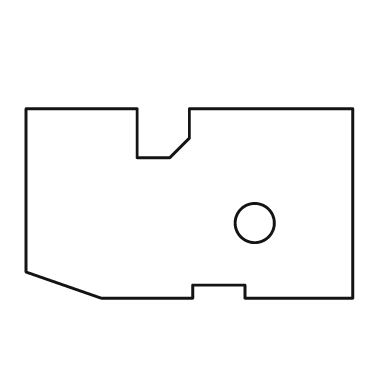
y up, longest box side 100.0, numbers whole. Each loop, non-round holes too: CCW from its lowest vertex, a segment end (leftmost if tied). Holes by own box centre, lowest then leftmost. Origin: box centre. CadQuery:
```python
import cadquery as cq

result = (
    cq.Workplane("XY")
    .moveTo(-27.0, -29.0)
    .lineTo(1.0, -29.0)
    .lineTo(1.0, -25.0)
    .lineTo(17.0, -25.0)
    .lineTo(17.0, -29.0)
    .lineTo(50.0, -29.0)
    .lineTo(50.0, 29.0)
    .lineTo(0.0, 29.0)
    .lineTo(0.0, 20.0)
    .lineTo(-6.0, 14.0)
    .lineTo(-16.0, 14.0)
    .lineTo(-16.0, 29.0)
    .lineTo(-50.0, 29.0)
    .lineTo(-50.0, -21.0)
    .close()
    .moveTo(20.0, -6.0)
    .circle(6.0)
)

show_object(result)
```